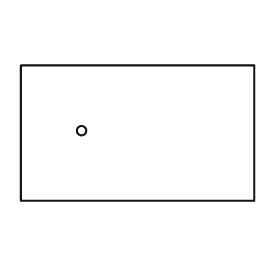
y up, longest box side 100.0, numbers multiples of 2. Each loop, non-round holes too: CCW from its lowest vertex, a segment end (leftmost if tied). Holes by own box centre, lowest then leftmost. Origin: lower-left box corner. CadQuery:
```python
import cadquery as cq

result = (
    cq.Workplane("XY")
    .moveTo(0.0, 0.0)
    .lineTo(100.0, 0.0)
    .lineTo(100.0, 58.0)
    .lineTo(0.0, 58.0)
    .close()
    .moveTo(26.0, 30.0)
    .circle(2.0)
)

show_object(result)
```